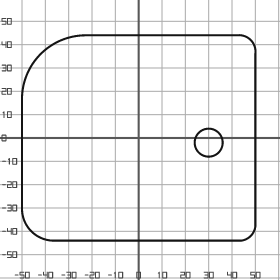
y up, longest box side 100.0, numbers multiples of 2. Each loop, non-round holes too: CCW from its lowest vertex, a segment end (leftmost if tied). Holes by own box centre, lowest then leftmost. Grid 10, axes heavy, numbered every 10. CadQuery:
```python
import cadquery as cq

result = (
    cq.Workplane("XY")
    .moveTo(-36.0, -44.0)
    .lineTo(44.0, -44.0)
    .threePointArc((48.0, -42.0), (50.0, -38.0))
    .lineTo(50.0, 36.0)
    .threePointArc((48.0, 42.0), (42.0, 44.0))
    .lineTo(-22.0, 44.0)
    .threePointArc((-42.0, 36.0), (-50.0, 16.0))
    .lineTo(-50.0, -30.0)
    .threePointArc((-46.0, -40.0), (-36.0, -44.0))
    .close()
    .moveTo(30.0, -2.0)
    .circle(6.0)
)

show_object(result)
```